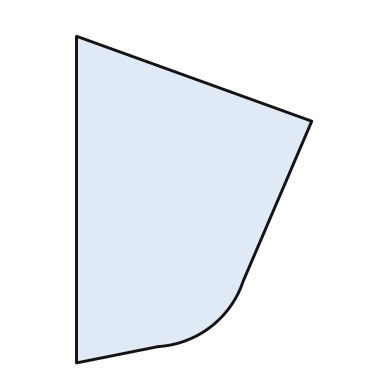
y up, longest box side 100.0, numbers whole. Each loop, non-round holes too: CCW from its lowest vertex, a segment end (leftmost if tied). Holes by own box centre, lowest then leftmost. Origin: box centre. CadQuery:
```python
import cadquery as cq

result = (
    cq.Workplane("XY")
    .moveTo(-36.0, -50.0)
    .lineTo(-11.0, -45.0)
    .threePointArc((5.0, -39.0), (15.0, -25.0))
    .lineTo(36.0, 24.0)
    .lineTo(-36.0, 50.0)
    .close()
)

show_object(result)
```